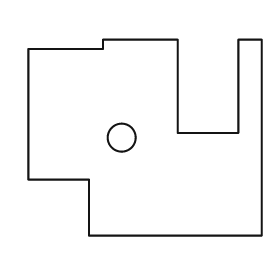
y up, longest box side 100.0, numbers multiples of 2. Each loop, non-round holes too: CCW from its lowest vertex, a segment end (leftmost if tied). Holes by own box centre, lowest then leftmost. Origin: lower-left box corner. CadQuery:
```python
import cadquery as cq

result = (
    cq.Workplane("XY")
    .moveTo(26.0, 0.0)
    .lineTo(100.0, 0.0)
    .lineTo(100.0, 84.0)
    .lineTo(90.0, 84.0)
    .lineTo(90.0, 44.0)
    .lineTo(64.0, 44.0)
    .lineTo(64.0, 84.0)
    .lineTo(32.0, 84.0)
    .lineTo(32.0, 80.0)
    .lineTo(0.0, 80.0)
    .lineTo(0.0, 24.0)
    .lineTo(26.0, 24.0)
    .close()
    .moveTo(40.0, 42.0)
    .circle(6.0)
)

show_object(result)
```